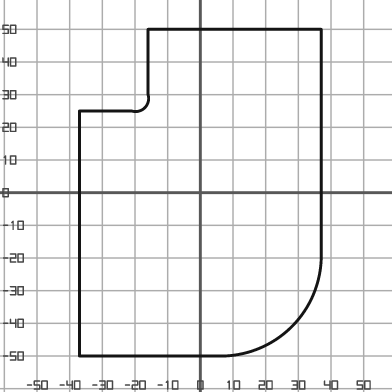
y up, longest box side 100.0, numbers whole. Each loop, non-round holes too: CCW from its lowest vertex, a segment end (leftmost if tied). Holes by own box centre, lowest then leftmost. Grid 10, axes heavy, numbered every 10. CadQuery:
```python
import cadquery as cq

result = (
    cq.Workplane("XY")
    .moveTo(-37.0, -50.0)
    .lineTo(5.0, -50.0)
    .threePointArc((28.0, -41.0), (37.0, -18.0))
    .lineTo(37.0, 50.0)
    .lineTo(-16.0, 50.0)
    .lineTo(-16.0, 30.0)
    .threePointArc((-17.0, 26.0), (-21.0, 25.0))
    .lineTo(-37.0, 25.0)
    .close()
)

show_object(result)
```